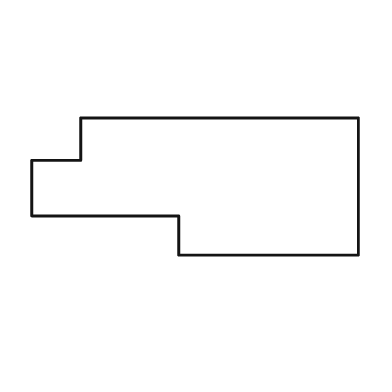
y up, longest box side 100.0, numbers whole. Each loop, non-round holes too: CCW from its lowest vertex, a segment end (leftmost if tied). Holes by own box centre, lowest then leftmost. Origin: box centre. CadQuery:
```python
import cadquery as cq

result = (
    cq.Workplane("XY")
    .moveTo(-5.0, -21.0)
    .lineTo(50.0, -21.0)
    .lineTo(50.0, 21.0)
    .lineTo(-35.0, 21.0)
    .lineTo(-35.0, 8.0)
    .lineTo(-50.0, 8.0)
    .lineTo(-50.0, -9.0)
    .lineTo(-5.0, -9.0)
    .close()
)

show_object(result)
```